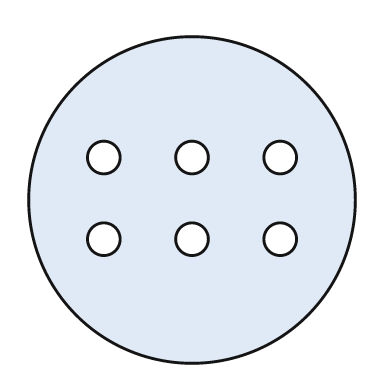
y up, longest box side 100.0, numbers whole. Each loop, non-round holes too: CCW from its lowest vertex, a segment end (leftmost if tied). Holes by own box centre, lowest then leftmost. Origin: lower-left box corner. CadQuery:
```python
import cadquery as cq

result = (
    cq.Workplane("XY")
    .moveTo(50.0, 50.0)
    .circle(50.0)
    .moveTo(23.0, 38.0)
    .circle(5.0)
    .moveTo(50.0, 38.0)
    .circle(5.0)
    .moveTo(77.0, 38.0)
    .circle(5.0)
    .moveTo(23.0, 63.0)
    .circle(5.0)
    .moveTo(50.0, 63.0)
    .circle(5.0)
    .moveTo(77.0, 63.0)
    .circle(5.0)
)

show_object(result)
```